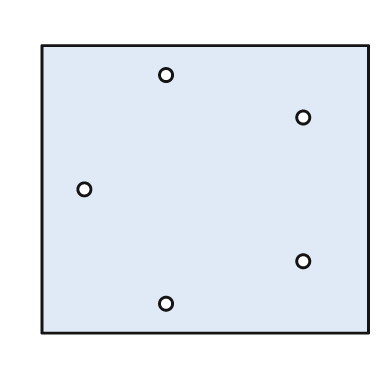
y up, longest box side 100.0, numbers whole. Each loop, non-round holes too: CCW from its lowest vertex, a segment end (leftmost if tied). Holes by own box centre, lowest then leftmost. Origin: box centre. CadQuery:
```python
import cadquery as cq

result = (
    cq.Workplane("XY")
    .moveTo(-50.0, -44.0)
    .lineTo(50.0, -44.0)
    .lineTo(50.0, 44.0)
    .lineTo(-50.0, 44.0)
    .close()
    .moveTo(-12.0, -35.0)
    .circle(2.0)
    .moveTo(30.0, -22.0)
    .circle(2.0)
    .moveTo(-37.0, 0.0)
    .circle(2.0)
    .moveTo(30.0, 22.0)
    .circle(2.0)
    .moveTo(-12.0, 35.0)
    .circle(2.0)
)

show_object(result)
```